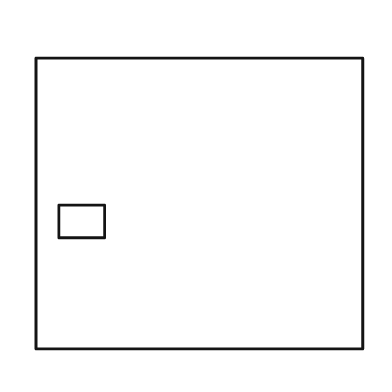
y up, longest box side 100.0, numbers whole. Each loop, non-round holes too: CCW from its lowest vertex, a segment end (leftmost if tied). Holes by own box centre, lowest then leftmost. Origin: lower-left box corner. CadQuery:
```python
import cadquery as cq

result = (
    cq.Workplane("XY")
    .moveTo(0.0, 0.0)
    .lineTo(100.0, 0.0)
    .lineTo(100.0, 89.0)
    .lineTo(0.0, 89.0)
    .close()
    .moveTo(7.0, 34.0)
    .lineTo(21.0, 34.0)
    .lineTo(21.0, 44.0)
    .lineTo(7.0, 44.0)
    .close()
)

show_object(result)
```